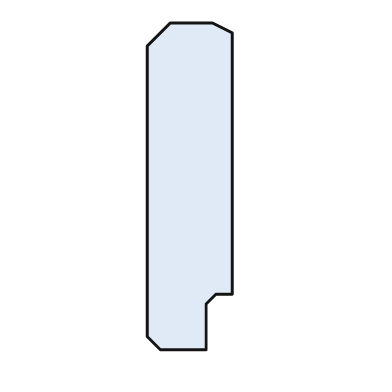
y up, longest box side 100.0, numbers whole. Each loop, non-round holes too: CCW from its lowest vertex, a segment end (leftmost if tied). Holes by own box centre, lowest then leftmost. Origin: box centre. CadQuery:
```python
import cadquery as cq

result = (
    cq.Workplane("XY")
    .moveTo(-9.0, -50.0)
    .lineTo(5.0, -50.0)
    .lineTo(5.0, -36.0)
    .lineTo(8.0, -33.0)
    .lineTo(13.0, -33.0)
    .lineTo(13.0, 47.0)
    .lineTo(7.0, 50.0)
    .lineTo(-6.0, 50.0)
    .lineTo(-13.0, 43.0)
    .lineTo(-13.0, -46.0)
    .close()
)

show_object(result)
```